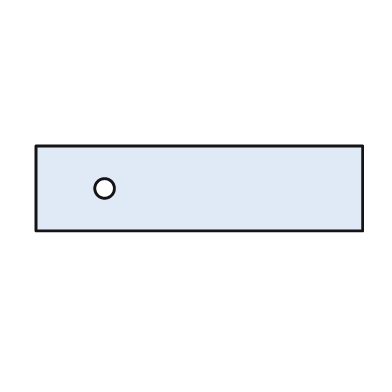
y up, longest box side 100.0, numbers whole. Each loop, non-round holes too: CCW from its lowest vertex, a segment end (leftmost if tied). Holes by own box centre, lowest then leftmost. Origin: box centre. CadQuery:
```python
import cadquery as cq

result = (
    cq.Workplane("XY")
    .moveTo(-50.0, -13.0)
    .lineTo(50.0, -13.0)
    .lineTo(50.0, 13.0)
    .lineTo(-50.0, 13.0)
    .close()
    .moveTo(-29.0, 0.0)
    .circle(3.0)
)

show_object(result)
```